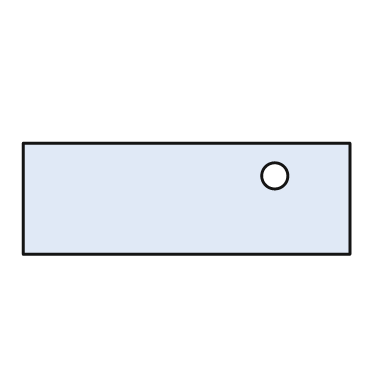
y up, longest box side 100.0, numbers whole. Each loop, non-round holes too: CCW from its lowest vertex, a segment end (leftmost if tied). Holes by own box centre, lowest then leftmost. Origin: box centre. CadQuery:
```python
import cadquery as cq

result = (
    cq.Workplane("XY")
    .moveTo(-50.0, -17.0)
    .lineTo(50.0, -17.0)
    .lineTo(50.0, 17.0)
    .lineTo(-50.0, 17.0)
    .close()
    .moveTo(27.0, 7.0)
    .circle(4.0)
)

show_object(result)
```